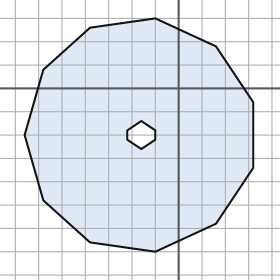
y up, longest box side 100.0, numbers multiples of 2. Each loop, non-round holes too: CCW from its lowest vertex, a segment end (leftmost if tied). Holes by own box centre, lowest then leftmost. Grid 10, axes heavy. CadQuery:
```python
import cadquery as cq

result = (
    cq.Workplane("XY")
    .moveTo(-10.0, -70.0)
    .lineTo(16.0, -58.0)
    .lineTo(32.0, -34.0)
    .lineTo(32.0, -6.0)
    .lineTo(16.0, 18.0)
    .lineTo(-10.0, 30.0)
    .lineTo(-38.0, 26.0)
    .lineTo(-58.0, 8.0)
    .lineTo(-66.0, -20.0)
    .lineTo(-58.0, -48.0)
    .lineTo(-38.0, -66.0)
    .close()
    .moveTo(-16.0, -26.0)
    .lineTo(-10.0, -22.0)
    .lineTo(-10.0, -18.0)
    .lineTo(-16.0, -14.0)
    .lineTo(-22.0, -18.0)
    .lineTo(-22.0, -22.0)
    .close()
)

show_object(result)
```